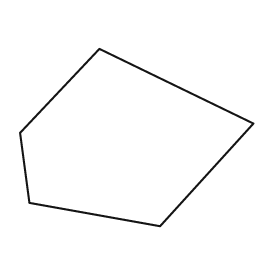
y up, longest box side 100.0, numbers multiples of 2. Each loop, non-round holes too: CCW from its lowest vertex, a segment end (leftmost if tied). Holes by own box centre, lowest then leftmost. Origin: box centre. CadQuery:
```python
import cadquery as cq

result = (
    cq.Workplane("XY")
    .moveTo(10.0, -38.0)
    .lineTo(50.0, 6.0)
    .lineTo(-16.0, 38.0)
    .lineTo(-50.0, 2.0)
    .lineTo(-46.0, -28.0)
    .close()
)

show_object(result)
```